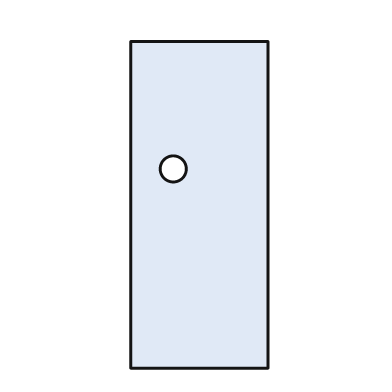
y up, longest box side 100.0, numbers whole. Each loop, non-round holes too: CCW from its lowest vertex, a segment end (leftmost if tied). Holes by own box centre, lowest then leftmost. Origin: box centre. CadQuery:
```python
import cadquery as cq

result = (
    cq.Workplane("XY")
    .moveTo(-21.0, -50.0)
    .lineTo(21.0, -50.0)
    .lineTo(21.0, 50.0)
    .lineTo(-21.0, 50.0)
    .close()
    .moveTo(-8.0, 11.0)
    .circle(4.0)
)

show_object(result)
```